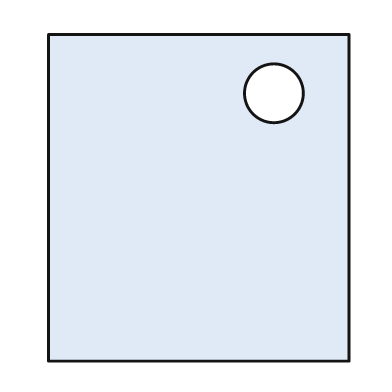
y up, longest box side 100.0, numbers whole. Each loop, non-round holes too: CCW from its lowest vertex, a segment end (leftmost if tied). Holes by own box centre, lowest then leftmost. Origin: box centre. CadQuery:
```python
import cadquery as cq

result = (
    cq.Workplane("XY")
    .moveTo(-46.0, -50.0)
    .lineTo(46.0, -50.0)
    .lineTo(46.0, 50.0)
    .lineTo(-46.0, 50.0)
    .close()
    .moveTo(23.0, 32.0)
    .circle(9.0)
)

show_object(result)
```